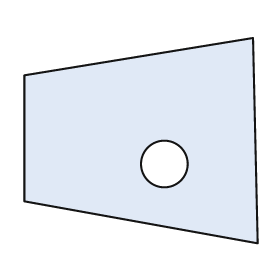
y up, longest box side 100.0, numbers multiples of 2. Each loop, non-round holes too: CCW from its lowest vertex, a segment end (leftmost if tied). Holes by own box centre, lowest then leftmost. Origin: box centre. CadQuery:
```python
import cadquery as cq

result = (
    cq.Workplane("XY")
    .moveTo(50.0, -44.0)
    .lineTo(48.0, 44.0)
    .lineTo(-50.0, 28.0)
    .lineTo(-50.0, -26.0)
    .close()
    .moveTo(10.0, -10.0)
    .circle(10.0)
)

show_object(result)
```